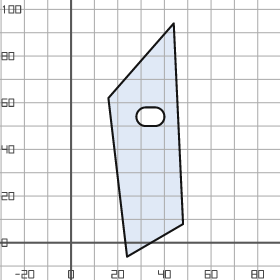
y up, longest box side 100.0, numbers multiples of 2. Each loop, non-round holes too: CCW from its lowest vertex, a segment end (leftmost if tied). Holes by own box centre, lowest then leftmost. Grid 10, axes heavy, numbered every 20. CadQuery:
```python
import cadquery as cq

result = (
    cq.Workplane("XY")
    .moveTo(24.0, -6.0)
    .lineTo(48.0, 8.0)
    .lineTo(44.0, 94.0)
    .lineTo(16.0, 62.0)
    .close()
    .moveTo(32.0, 50.0)
    .lineTo(36.0, 50.0)
    .threePointArc((40.0, 54.0), (36.0, 58.0))
    .lineTo(32.0, 58.0)
    .threePointArc((28.0, 54.0), (32.0, 50.0))
    .close()
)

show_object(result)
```